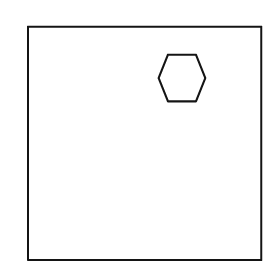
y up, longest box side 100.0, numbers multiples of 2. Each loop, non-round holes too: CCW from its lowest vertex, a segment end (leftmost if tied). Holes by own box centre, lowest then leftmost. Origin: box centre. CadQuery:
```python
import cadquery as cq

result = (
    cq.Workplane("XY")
    .moveTo(-50.0, -50.0)
    .lineTo(50.0, -50.0)
    .lineTo(50.0, 50.0)
    .lineTo(-50.0, 50.0)
    .close()
    .moveTo(10.0, 18.0)
    .lineTo(22.0, 18.0)
    .lineTo(26.0, 28.0)
    .lineTo(22.0, 38.0)
    .lineTo(10.0, 38.0)
    .lineTo(6.0, 28.0)
    .close()
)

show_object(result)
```